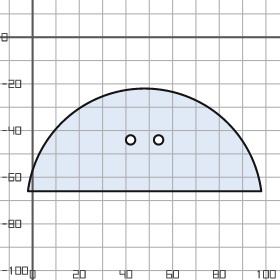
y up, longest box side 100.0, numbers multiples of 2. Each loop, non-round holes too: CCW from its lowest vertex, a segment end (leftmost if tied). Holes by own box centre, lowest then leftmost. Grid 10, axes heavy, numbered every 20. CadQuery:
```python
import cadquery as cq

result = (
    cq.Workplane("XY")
    .moveTo(-2.0, -66.0)
    .lineTo(98.0, -66.0)
    .threePointArc((48.0, -22.0), (-2.0, -66.0))
    .close()
    .moveTo(42.0, -44.0)
    .circle(2.0)
    .moveTo(54.0, -44.0)
    .circle(2.0)
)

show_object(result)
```